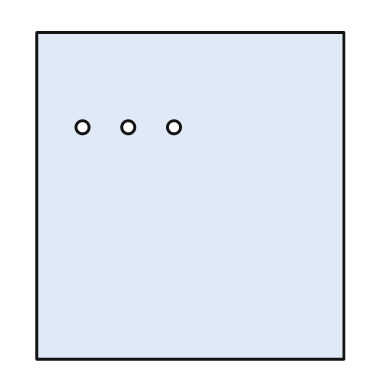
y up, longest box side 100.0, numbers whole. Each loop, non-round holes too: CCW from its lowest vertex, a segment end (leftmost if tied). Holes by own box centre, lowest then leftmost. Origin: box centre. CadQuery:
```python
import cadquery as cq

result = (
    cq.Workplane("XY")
    .moveTo(-47.0, -50.0)
    .lineTo(47.0, -50.0)
    .lineTo(47.0, 50.0)
    .lineTo(-47.0, 50.0)
    .close()
    .moveTo(-33.0, 21.0)
    .circle(2.0)
    .moveTo(-19.0, 21.0)
    .circle(2.0)
    .moveTo(-5.0, 21.0)
    .circle(2.0)
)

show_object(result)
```